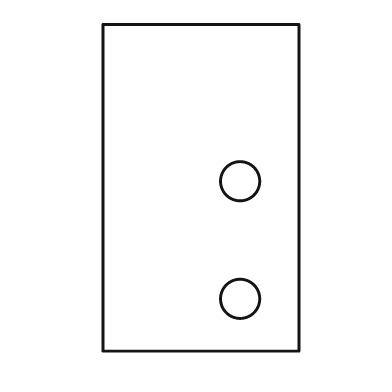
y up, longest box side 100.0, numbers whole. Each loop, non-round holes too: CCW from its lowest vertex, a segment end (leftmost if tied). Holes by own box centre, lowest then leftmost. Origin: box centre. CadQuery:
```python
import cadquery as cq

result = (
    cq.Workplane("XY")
    .moveTo(-30.0, -50.0)
    .lineTo(30.0, -50.0)
    .lineTo(30.0, 50.0)
    .lineTo(-30.0, 50.0)
    .close()
    .moveTo(12.0, -34.0)
    .circle(6.0)
    .moveTo(12.0, 2.0)
    .circle(6.0)
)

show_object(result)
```